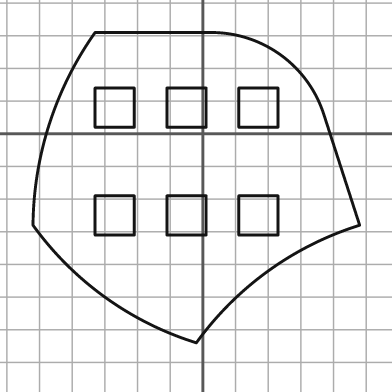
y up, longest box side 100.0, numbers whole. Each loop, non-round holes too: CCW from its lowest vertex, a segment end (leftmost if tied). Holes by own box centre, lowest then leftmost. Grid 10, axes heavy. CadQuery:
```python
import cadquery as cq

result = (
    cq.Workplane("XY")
    .moveTo(-2.0, -64.0)
    .threePointArc((20.0, -42.0), (48.0, -28.0))
    .lineTo(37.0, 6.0)
    .threePointArc((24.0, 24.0), (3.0, 31.0))
    .lineTo(-33.0, 31.0)
    .threePointArc((-47.0, 3.0), (-52.0, -28.0))
    .threePointArc((-30.0, -50.0), (-2.0, -64.0))
    .close()
    .moveTo(-33.0, -31.0)
    .lineTo(-21.0, -31.0)
    .lineTo(-21.0, -19.0)
    .lineTo(-33.0, -19.0)
    .close()
    .moveTo(-11.0, -31.0)
    .lineTo(1.0, -31.0)
    .lineTo(1.0, -19.0)
    .lineTo(-11.0, -19.0)
    .close()
    .moveTo(11.0, -31.0)
    .lineTo(23.0, -31.0)
    .lineTo(23.0, -19.0)
    .lineTo(11.0, -19.0)
    .close()
    .moveTo(-33.0, 2.0)
    .lineTo(-21.0, 2.0)
    .lineTo(-21.0, 14.0)
    .lineTo(-33.0, 14.0)
    .close()
    .moveTo(-11.0, 2.0)
    .lineTo(1.0, 2.0)
    .lineTo(1.0, 14.0)
    .lineTo(-11.0, 14.0)
    .close()
    .moveTo(11.0, 2.0)
    .lineTo(23.0, 2.0)
    .lineTo(23.0, 14.0)
    .lineTo(11.0, 14.0)
    .close()
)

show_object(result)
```